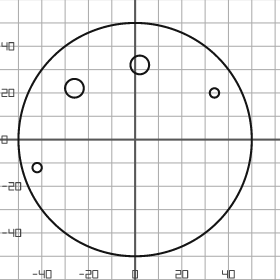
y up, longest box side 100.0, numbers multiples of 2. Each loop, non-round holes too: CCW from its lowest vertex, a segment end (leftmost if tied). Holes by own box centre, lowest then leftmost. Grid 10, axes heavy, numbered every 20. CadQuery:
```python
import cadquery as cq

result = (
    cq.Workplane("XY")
    .moveTo(0.0, 0.0)
    .circle(50.0)
    .moveTo(-42.0, -12.0)
    .circle(2.0)
    .moveTo(34.0, 20.0)
    .circle(2.0)
    .moveTo(-26.0, 22.0)
    .circle(4.0)
    .moveTo(2.0, 32.0)
    .circle(4.0)
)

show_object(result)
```